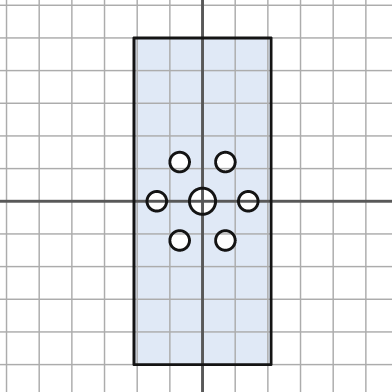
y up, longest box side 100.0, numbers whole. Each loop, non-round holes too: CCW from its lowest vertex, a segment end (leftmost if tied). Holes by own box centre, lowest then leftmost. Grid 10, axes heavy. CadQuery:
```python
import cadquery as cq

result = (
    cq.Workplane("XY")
    .moveTo(-21.0, -50.0)
    .lineTo(21.0, -50.0)
    .lineTo(21.0, 50.0)
    .lineTo(-21.0, 50.0)
    .close()
    .moveTo(-7.0, -12.0)
    .circle(3.0)
    .moveTo(7.0, -12.0)
    .circle(3.0)
    .moveTo(-14.0, 0.0)
    .circle(3.0)
    .moveTo(0.0, 0.0)
    .circle(4.0)
    .moveTo(14.0, 0.0)
    .circle(3.0)
    .moveTo(-7.0, 12.0)
    .circle(3.0)
    .moveTo(7.0, 12.0)
    .circle(3.0)
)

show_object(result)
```